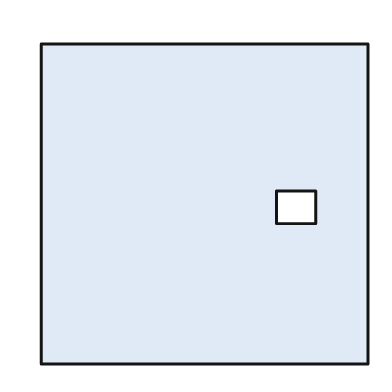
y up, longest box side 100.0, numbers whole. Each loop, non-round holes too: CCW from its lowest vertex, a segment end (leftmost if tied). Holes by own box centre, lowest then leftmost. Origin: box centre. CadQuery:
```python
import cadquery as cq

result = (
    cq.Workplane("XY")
    .moveTo(-50.0, -49.0)
    .lineTo(50.0, -49.0)
    .lineTo(50.0, 49.0)
    .lineTo(-50.0, 49.0)
    .close()
    .moveTo(22.0, -6.0)
    .lineTo(34.0, -6.0)
    .lineTo(34.0, 4.0)
    .lineTo(22.0, 4.0)
    .close()
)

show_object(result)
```